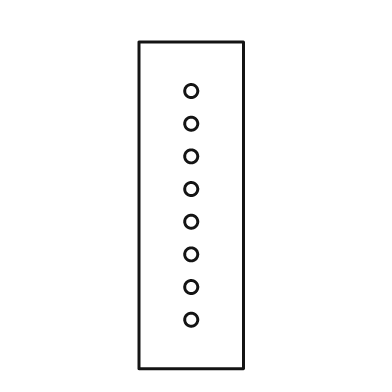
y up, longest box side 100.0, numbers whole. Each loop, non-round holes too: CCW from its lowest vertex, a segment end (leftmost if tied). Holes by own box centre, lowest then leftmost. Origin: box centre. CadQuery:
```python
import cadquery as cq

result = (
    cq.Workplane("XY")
    .moveTo(-16.0, -50.0)
    .lineTo(16.0, -50.0)
    .lineTo(16.0, 50.0)
    .lineTo(-16.0, 50.0)
    .close()
    .moveTo(0.0, -35.0)
    .circle(2.0)
    .moveTo(0.0, -25.0)
    .circle(2.0)
    .moveTo(0.0, -15.0)
    .circle(2.0)
    .moveTo(0.0, -5.0)
    .circle(2.0)
    .moveTo(0.0, 5.0)
    .circle(2.0)
    .moveTo(0.0, 15.0)
    .circle(2.0)
    .moveTo(0.0, 25.0)
    .circle(2.0)
    .moveTo(0.0, 35.0)
    .circle(2.0)
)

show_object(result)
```